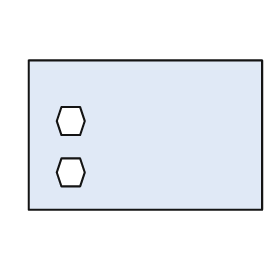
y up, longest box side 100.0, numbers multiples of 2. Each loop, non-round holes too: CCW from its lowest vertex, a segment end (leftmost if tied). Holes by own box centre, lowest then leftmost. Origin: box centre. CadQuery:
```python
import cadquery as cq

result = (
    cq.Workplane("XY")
    .moveTo(-50.0, -32.0)
    .lineTo(50.0, -32.0)
    .lineTo(50.0, 32.0)
    .lineTo(-50.0, 32.0)
    .close()
    .moveTo(-36.0, -22.0)
    .lineTo(-28.0, -22.0)
    .lineTo(-26.0, -16.0)
    .lineTo(-28.0, -10.0)
    .lineTo(-36.0, -10.0)
    .lineTo(-38.0, -16.0)
    .close()
    .moveTo(-36.0, 0.0)
    .lineTo(-28.0, 0.0)
    .lineTo(-26.0, 6.0)
    .lineTo(-28.0, 12.0)
    .lineTo(-36.0, 12.0)
    .lineTo(-38.0, 6.0)
    .close()
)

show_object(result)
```